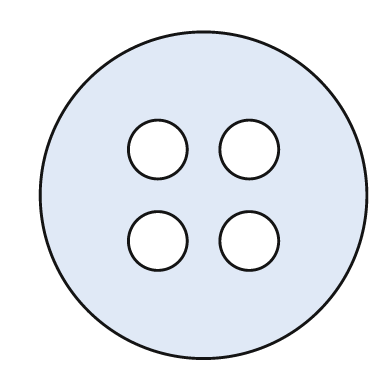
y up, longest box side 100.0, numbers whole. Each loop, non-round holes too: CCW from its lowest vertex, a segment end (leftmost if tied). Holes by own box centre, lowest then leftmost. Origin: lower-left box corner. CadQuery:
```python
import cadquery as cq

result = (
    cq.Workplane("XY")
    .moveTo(50.0, 50.0)
    .circle(50.0)
    .moveTo(36.0, 36.0)
    .circle(9.0)
    .moveTo(64.0, 36.0)
    .circle(9.0)
    .moveTo(36.0, 64.0)
    .circle(9.0)
    .moveTo(64.0, 64.0)
    .circle(9.0)
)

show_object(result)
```